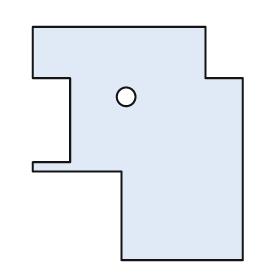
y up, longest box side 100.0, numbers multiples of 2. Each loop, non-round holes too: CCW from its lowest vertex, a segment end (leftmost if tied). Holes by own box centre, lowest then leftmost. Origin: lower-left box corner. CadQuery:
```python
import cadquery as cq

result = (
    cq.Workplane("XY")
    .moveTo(38.0, 0.0)
    .lineTo(90.0, 0.0)
    .lineTo(90.0, 78.0)
    .lineTo(74.0, 78.0)
    .lineTo(74.0, 100.0)
    .lineTo(0.0, 100.0)
    .lineTo(0.0, 78.0)
    .lineTo(16.0, 78.0)
    .lineTo(16.0, 42.0)
    .lineTo(0.0, 42.0)
    .lineTo(0.0, 38.0)
    .lineTo(38.0, 38.0)
    .close()
    .moveTo(40.0, 70.0)
    .circle(4.0)
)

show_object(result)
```